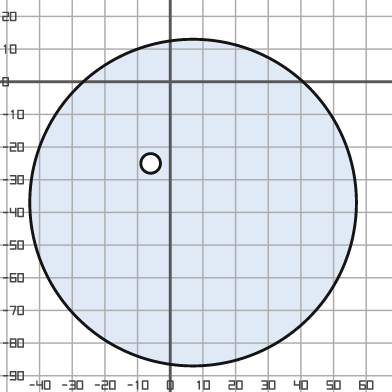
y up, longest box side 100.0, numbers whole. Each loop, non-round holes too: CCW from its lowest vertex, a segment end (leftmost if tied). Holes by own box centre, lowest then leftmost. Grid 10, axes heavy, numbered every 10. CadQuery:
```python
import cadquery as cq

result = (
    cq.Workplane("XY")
    .moveTo(7.0, -37.0)
    .circle(50.0)
    .moveTo(-6.0, -25.0)
    .circle(3.0)
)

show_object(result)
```